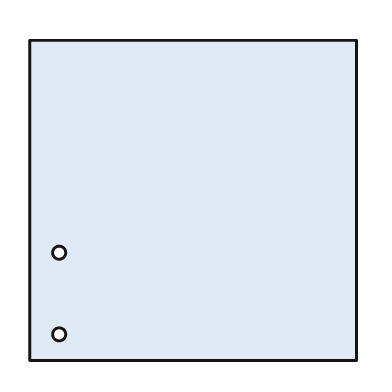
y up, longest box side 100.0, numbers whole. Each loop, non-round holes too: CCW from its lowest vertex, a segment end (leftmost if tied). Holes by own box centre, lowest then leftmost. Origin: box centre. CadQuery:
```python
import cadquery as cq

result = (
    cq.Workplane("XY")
    .moveTo(-50.0, -49.0)
    .lineTo(50.0, -49.0)
    .lineTo(50.0, 49.0)
    .lineTo(-50.0, 49.0)
    .close()
    .moveTo(-41.0, -41.0)
    .circle(2.0)
    .moveTo(-41.0, -16.0)
    .circle(2.0)
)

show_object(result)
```